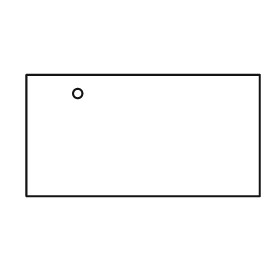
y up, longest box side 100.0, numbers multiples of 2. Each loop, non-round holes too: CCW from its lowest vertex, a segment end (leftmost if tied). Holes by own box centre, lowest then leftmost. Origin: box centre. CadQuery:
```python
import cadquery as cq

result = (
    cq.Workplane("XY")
    .moveTo(-50.0, -26.0)
    .lineTo(50.0, -26.0)
    .lineTo(50.0, 26.0)
    .lineTo(-50.0, 26.0)
    .close()
    .moveTo(-28.0, 18.0)
    .circle(2.0)
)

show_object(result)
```